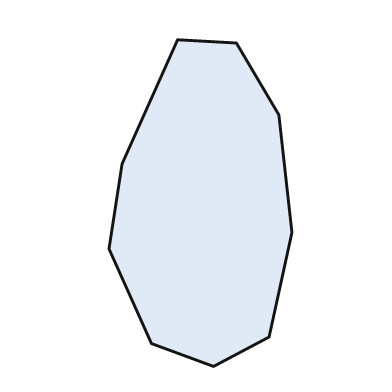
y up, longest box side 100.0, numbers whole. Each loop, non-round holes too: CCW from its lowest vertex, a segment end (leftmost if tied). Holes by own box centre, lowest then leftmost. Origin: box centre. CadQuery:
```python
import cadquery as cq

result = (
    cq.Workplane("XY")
    .moveTo(4.0, -50.0)
    .lineTo(21.0, -41.0)
    .lineTo(28.0, -9.0)
    .lineTo(24.0, 27.0)
    .lineTo(11.0, 49.0)
    .lineTo(-7.0, 50.0)
    .lineTo(-24.0, 12.0)
    .lineTo(-28.0, -14.0)
    .lineTo(-15.0, -43.0)
    .close()
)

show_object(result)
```